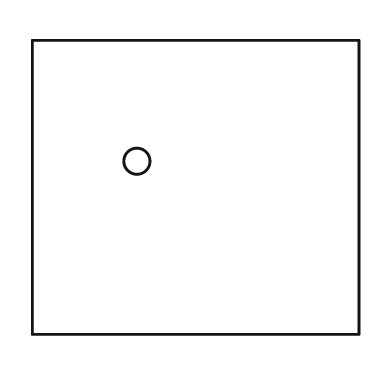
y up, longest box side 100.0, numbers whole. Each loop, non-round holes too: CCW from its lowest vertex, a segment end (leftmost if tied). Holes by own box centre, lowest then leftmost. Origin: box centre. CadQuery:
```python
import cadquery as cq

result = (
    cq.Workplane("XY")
    .moveTo(-50.0, -45.0)
    .lineTo(50.0, -45.0)
    .lineTo(50.0, 45.0)
    .lineTo(-50.0, 45.0)
    .close()
    .moveTo(-18.0, 8.0)
    .circle(4.0)
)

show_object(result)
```